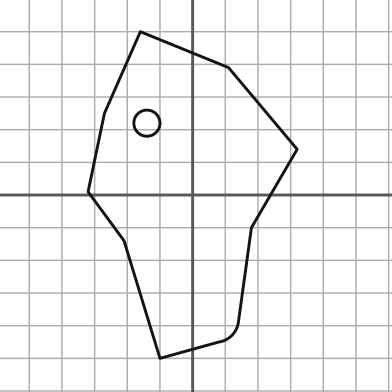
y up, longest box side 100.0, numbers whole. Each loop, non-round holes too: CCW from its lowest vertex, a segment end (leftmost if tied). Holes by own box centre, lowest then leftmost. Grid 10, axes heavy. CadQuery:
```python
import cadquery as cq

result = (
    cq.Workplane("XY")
    .moveTo(-10.0, -50.0)
    .lineTo(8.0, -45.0)
    .threePointArc((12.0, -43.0), (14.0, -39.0))
    .lineTo(18.0, -10.0)
    .lineTo(32.0, 14.0)
    .lineTo(11.0, 39.0)
    .lineTo(-16.0, 50.0)
    .lineTo(-27.0, 25.0)
    .lineTo(-32.0, 1.0)
    .lineTo(-21.0, -14.0)
    .close()
    .moveTo(-14.0, 22.0)
    .circle(4.0)
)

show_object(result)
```